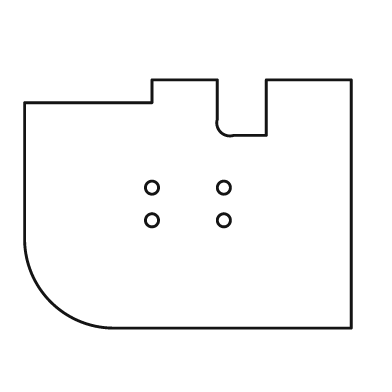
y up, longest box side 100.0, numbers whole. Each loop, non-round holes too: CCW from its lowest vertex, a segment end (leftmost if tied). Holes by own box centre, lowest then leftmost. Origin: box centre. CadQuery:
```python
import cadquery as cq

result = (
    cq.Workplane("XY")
    .moveTo(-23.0, -38.0)
    .lineTo(50.0, -38.0)
    .lineTo(50.0, 38.0)
    .lineTo(24.0, 38.0)
    .lineTo(24.0, 21.0)
    .lineTo(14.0, 21.0)
    .threePointArc((10.0, 22.0), (9.0, 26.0))
    .lineTo(9.0, 38.0)
    .lineTo(-11.0, 38.0)
    .lineTo(-11.0, 31.0)
    .lineTo(-50.0, 31.0)
    .lineTo(-50.0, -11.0)
    .threePointArc((-42.0, -30.0), (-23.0, -38.0))
    .close()
    .moveTo(-11.0, -5.0)
    .circle(2.0)
    .moveTo(11.0, -5.0)
    .circle(2.0)
    .moveTo(-11.0, 5.0)
    .circle(2.0)
    .moveTo(11.0, 5.0)
    .circle(2.0)
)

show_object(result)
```